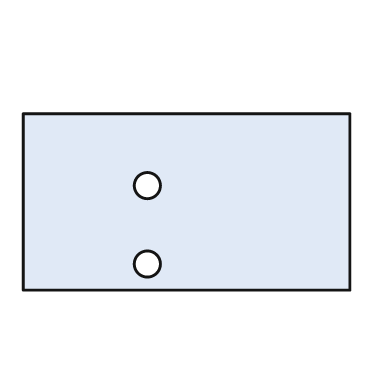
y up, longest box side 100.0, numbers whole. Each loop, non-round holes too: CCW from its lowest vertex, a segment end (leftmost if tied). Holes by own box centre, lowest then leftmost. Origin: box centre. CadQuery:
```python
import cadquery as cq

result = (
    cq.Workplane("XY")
    .moveTo(-50.0, -27.0)
    .lineTo(50.0, -27.0)
    .lineTo(50.0, 27.0)
    .lineTo(-50.0, 27.0)
    .close()
    .moveTo(-12.0, -19.0)
    .circle(4.0)
    .moveTo(-12.0, 5.0)
    .circle(4.0)
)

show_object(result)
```